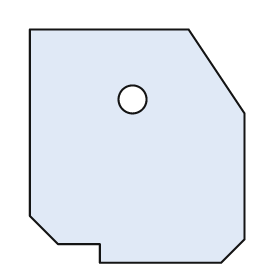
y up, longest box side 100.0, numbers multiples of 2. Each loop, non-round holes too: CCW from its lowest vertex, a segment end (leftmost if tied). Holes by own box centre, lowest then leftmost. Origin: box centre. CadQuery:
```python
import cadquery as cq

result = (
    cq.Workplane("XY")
    .moveTo(-16.0, -50.0)
    .lineTo(36.0, -50.0)
    .lineTo(46.0, -40.0)
    .lineTo(46.0, 14.0)
    .lineTo(22.0, 50.0)
    .lineTo(-46.0, 50.0)
    .lineTo(-46.0, -30.0)
    .lineTo(-34.0, -42.0)
    .lineTo(-16.0, -42.0)
    .close()
    .moveTo(-2.0, 20.0)
    .circle(6.0)
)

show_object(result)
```